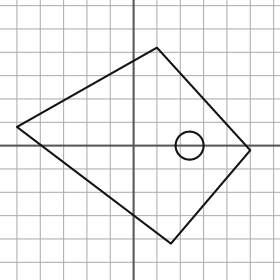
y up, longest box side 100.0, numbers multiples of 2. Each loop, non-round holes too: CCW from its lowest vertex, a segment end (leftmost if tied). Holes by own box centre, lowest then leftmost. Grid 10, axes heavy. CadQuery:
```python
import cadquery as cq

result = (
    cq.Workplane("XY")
    .moveTo(16.0, -42.0)
    .lineTo(50.0, -2.0)
    .lineTo(10.0, 42.0)
    .lineTo(-50.0, 8.0)
    .close()
    .moveTo(24.0, 0.0)
    .circle(6.0)
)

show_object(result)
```